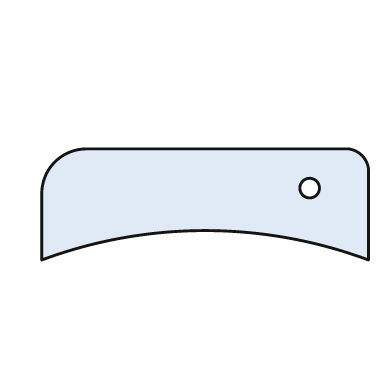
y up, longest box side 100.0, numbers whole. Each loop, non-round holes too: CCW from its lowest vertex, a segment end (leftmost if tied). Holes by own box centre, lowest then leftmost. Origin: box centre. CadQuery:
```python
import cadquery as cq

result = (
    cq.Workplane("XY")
    .moveTo(-50.0, -17.0)
    .threePointArc((0.0, -8.0), (50.0, -17.0))
    .lineTo(50.0, 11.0)
    .threePointArc((48.0, 15.0), (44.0, 17.0))
    .lineTo(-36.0, 17.0)
    .threePointArc((-46.0, 13.0), (-50.0, 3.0))
    .close()
    .moveTo(32.0, 5.0)
    .circle(3.0)
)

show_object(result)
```